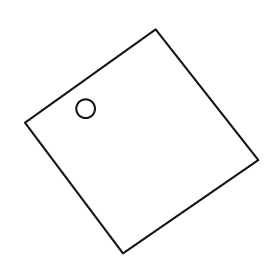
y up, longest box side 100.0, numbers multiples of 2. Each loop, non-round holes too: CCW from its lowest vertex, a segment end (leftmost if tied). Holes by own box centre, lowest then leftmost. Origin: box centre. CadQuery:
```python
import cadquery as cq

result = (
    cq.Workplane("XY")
    .moveTo(-8.0, -48.0)
    .lineTo(50.0, -8.0)
    .lineTo(6.0, 48.0)
    .lineTo(-50.0, 8.0)
    .close()
    .moveTo(-24.0, 14.0)
    .circle(4.0)
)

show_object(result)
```